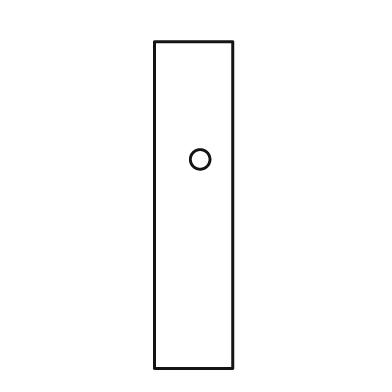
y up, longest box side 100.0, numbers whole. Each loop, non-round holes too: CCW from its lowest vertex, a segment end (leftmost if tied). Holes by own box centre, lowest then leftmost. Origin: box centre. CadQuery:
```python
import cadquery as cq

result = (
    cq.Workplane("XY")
    .moveTo(-12.0, -50.0)
    .lineTo(12.0, -50.0)
    .lineTo(12.0, 50.0)
    .lineTo(-12.0, 50.0)
    .close()
    .moveTo(2.0, 14.0)
    .circle(3.0)
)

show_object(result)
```